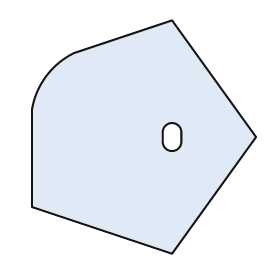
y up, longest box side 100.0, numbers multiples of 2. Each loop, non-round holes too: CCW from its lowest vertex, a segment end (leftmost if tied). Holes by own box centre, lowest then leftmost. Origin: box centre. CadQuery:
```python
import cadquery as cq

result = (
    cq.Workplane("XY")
    .moveTo(12.0, -50.0)
    .lineTo(48.0, 0.0)
    .lineTo(12.0, 50.0)
    .lineTo(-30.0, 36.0)
    .threePointArc((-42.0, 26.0), (-48.0, 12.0))
    .lineTo(-48.0, -30.0)
    .close()
    .moveTo(8.0, -2.0)
    .threePointArc((12.0, -6.0), (16.0, -2.0))
    .lineTo(16.0, 2.0)
    .threePointArc((12.0, 6.0), (8.0, 2.0))
    .close()
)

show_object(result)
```